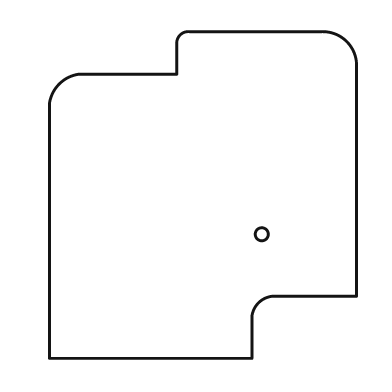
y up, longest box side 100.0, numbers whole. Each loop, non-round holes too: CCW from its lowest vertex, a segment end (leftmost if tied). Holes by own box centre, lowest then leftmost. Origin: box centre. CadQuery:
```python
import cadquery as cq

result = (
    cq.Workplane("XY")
    .moveTo(-47.0, -50.0)
    .lineTo(15.0, -50.0)
    .lineTo(15.0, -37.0)
    .threePointArc((17.0, -33.0), (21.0, -31.0))
    .lineTo(47.0, -31.0)
    .lineTo(47.0, 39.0)
    .threePointArc((44.0, 47.0), (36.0, 50.0))
    .lineTo(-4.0, 50.0)
    .threePointArc((-7.0, 49.0), (-8.0, 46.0))
    .lineTo(-8.0, 37.0)
    .lineTo(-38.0, 37.0)
    .threePointArc((-44.0, 34.0), (-47.0, 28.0))
    .close()
    .moveTo(18.0, -12.0)
    .circle(2.0)
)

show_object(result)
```